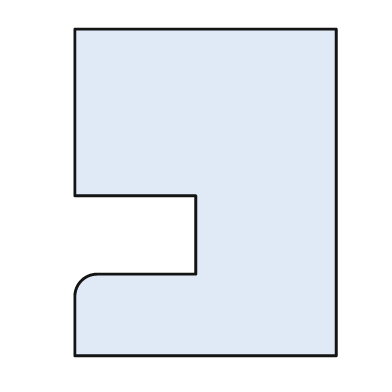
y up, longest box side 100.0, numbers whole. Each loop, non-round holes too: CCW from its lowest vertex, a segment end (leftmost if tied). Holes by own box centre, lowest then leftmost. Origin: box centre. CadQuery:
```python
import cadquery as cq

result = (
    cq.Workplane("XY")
    .moveTo(-40.0, -50.0)
    .lineTo(40.0, -50.0)
    .lineTo(40.0, 50.0)
    .lineTo(-40.0, 50.0)
    .lineTo(-40.0, -1.0)
    .lineTo(-3.0, -1.0)
    .lineTo(-3.0, -25.0)
    .lineTo(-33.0, -25.0)
    .threePointArc((-38.0, -27.0), (-40.0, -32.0))
    .close()
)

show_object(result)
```